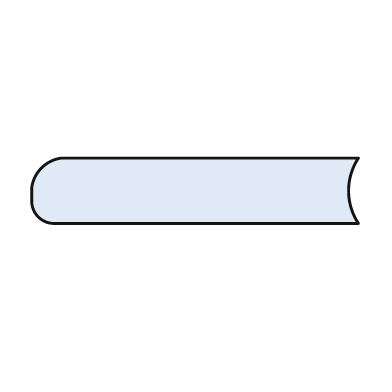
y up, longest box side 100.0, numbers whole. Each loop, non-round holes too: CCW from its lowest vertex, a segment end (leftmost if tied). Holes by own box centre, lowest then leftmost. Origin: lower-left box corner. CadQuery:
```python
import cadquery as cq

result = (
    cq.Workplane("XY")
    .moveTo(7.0, 0.0)
    .lineTo(100.0, 0.0)
    .threePointArc((97.0, 10.0), (100.0, 20.0))
    .lineTo(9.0, 20.0)
    .threePointArc((3.0, 17.0), (0.0, 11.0))
    .lineTo(0.0, 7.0)
    .threePointArc((2.0, 2.0), (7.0, 0.0))
    .close()
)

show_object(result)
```